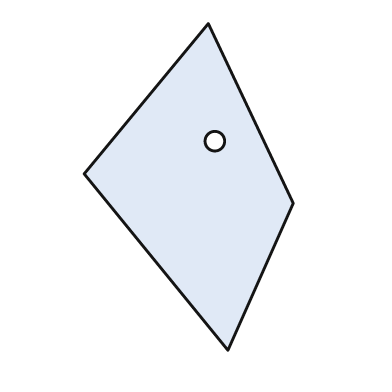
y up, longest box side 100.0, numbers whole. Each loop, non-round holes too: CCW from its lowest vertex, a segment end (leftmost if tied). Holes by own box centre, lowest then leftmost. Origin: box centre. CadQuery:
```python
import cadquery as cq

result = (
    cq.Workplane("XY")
    .moveTo(12.0, -50.0)
    .lineTo(32.0, -5.0)
    .lineTo(6.0, 50.0)
    .lineTo(-32.0, 4.0)
    .close()
    .moveTo(8.0, 14.0)
    .circle(3.0)
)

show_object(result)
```